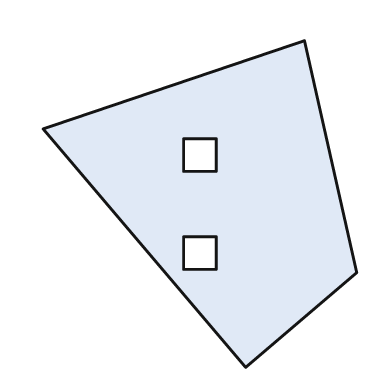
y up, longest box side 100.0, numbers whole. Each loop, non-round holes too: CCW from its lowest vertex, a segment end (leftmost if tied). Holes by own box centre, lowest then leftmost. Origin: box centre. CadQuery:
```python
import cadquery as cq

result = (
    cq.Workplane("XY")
    .moveTo(14.0, -50.0)
    .lineTo(48.0, -21.0)
    .lineTo(32.0, 50.0)
    .lineTo(-48.0, 23.0)
    .close()
    .moveTo(-5.0, -20.0)
    .lineTo(5.0, -20.0)
    .lineTo(5.0, -10.0)
    .lineTo(-5.0, -10.0)
    .close()
    .moveTo(-5.0, 10.0)
    .lineTo(5.0, 10.0)
    .lineTo(5.0, 20.0)
    .lineTo(-5.0, 20.0)
    .close()
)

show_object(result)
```